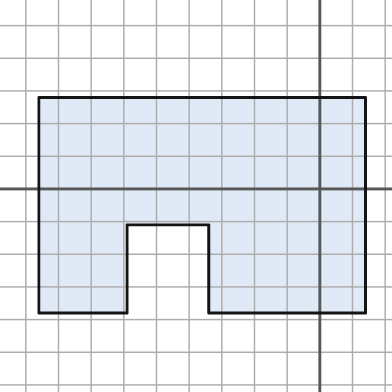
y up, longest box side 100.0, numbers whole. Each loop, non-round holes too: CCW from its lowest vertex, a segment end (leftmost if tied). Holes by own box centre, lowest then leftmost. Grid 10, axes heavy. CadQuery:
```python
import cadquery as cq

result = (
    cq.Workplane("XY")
    .moveTo(-86.0, -38.0)
    .lineTo(-59.0, -38.0)
    .lineTo(-59.0, -11.0)
    .lineTo(-34.0, -11.0)
    .lineTo(-34.0, -38.0)
    .lineTo(14.0, -38.0)
    .lineTo(14.0, 28.0)
    .lineTo(-86.0, 28.0)
    .close()
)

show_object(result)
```